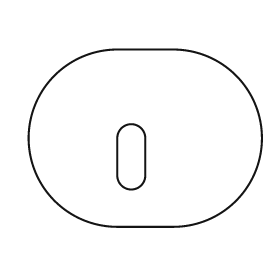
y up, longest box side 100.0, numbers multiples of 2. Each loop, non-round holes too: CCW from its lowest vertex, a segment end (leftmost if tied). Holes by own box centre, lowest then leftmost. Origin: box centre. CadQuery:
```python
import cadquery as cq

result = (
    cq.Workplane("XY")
    .moveTo(-12.0, -38.0)
    .lineTo(12.0, -38.0)
    .threePointArc((50.0, 0.0), (12.0, 38.0))
    .lineTo(-12.0, 38.0)
    .threePointArc((-50.0, 0.0), (-12.0, -38.0))
    .close()
    .moveTo(-12.0, -16.0)
    .threePointArc((-6.0, -22.0), (0.0, -16.0))
    .lineTo(0.0, 0.0)
    .threePointArc((-6.0, 6.0), (-12.0, 0.0))
    .close()
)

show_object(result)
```